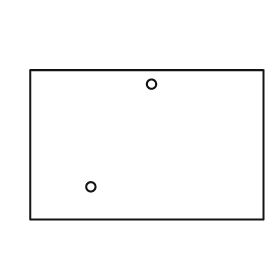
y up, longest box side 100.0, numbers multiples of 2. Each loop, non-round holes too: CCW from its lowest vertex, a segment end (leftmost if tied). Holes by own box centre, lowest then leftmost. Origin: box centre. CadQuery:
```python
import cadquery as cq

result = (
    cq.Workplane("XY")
    .moveTo(-50.0, -32.0)
    .lineTo(50.0, -32.0)
    .lineTo(50.0, 32.0)
    .lineTo(-50.0, 32.0)
    .close()
    .moveTo(-24.0, -18.0)
    .circle(2.0)
    .moveTo(2.0, 26.0)
    .circle(2.0)
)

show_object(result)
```